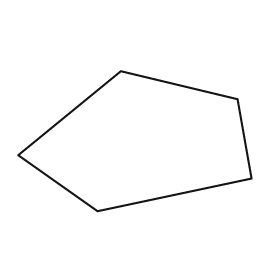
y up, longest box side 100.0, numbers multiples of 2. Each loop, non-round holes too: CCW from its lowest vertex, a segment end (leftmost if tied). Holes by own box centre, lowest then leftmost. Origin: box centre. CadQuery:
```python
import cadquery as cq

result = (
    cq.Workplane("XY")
    .moveTo(-16.0, -30.0)
    .lineTo(50.0, -16.0)
    .lineTo(44.0, 18.0)
    .lineTo(-6.0, 30.0)
    .lineTo(-50.0, -6.0)
    .close()
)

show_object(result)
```